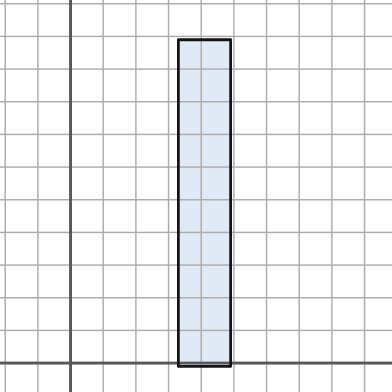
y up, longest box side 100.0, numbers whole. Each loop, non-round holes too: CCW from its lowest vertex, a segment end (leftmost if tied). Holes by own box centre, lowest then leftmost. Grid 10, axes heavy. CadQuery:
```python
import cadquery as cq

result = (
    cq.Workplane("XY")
    .moveTo(33.0, -1.0)
    .lineTo(49.0, -1.0)
    .lineTo(49.0, 99.0)
    .lineTo(33.0, 99.0)
    .close()
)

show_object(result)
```